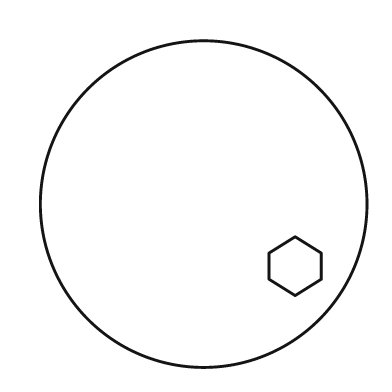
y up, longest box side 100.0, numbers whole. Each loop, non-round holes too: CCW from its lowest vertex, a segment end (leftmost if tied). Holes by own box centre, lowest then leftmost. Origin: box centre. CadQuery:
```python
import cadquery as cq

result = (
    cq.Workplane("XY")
    .moveTo(0.0, 0.0)
    .circle(50.0)
    .moveTo(28.0, -28.0)
    .lineTo(36.0, -23.0)
    .lineTo(36.0, -15.0)
    .lineTo(28.0, -10.0)
    .lineTo(20.0, -15.0)
    .lineTo(20.0, -23.0)
    .close()
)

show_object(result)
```